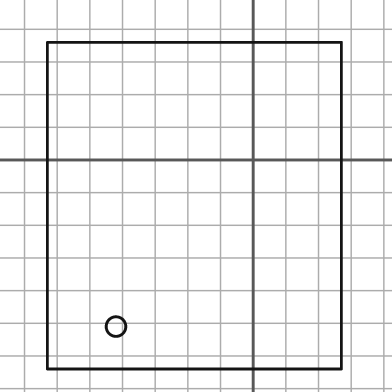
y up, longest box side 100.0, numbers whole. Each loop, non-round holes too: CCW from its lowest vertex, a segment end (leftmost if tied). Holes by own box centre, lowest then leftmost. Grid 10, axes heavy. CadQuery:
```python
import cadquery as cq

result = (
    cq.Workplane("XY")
    .moveTo(-63.0, -64.0)
    .lineTo(27.0, -64.0)
    .lineTo(27.0, 36.0)
    .lineTo(-63.0, 36.0)
    .close()
    .moveTo(-42.0, -51.0)
    .circle(3.0)
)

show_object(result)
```